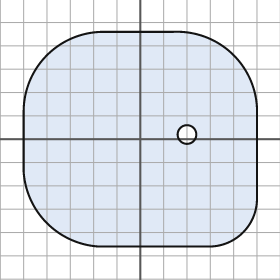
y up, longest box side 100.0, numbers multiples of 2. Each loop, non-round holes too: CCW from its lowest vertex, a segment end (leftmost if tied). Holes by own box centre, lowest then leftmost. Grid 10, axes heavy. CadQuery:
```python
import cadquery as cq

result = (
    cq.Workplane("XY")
    .moveTo(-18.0, -46.0)
    .lineTo(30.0, -46.0)
    .threePointArc((44.0, -40.0), (50.0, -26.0))
    .lineTo(50.0, 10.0)
    .threePointArc((40.0, 36.0), (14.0, 46.0))
    .lineTo(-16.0, 46.0)
    .threePointArc((-40.0, 36.0), (-50.0, 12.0))
    .lineTo(-50.0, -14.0)
    .threePointArc((-40.0, -36.0), (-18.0, -46.0))
    .close()
    .moveTo(20.0, 2.0)
    .circle(4.0)
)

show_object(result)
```